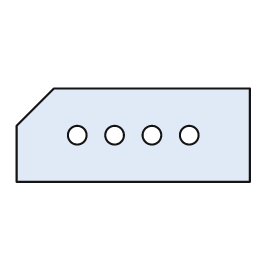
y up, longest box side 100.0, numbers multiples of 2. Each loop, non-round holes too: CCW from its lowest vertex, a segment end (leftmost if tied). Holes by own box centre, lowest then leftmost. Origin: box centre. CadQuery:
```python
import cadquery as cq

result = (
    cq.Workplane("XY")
    .moveTo(-50.0, -20.0)
    .lineTo(50.0, -20.0)
    .lineTo(50.0, 20.0)
    .lineTo(-34.0, 20.0)
    .lineTo(-50.0, 4.0)
    .close()
    .moveTo(-24.0, 0.0)
    .circle(4.0)
    .moveTo(-8.0, 0.0)
    .circle(4.0)
    .moveTo(8.0, 0.0)
    .circle(4.0)
    .moveTo(24.0, 0.0)
    .circle(4.0)
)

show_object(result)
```